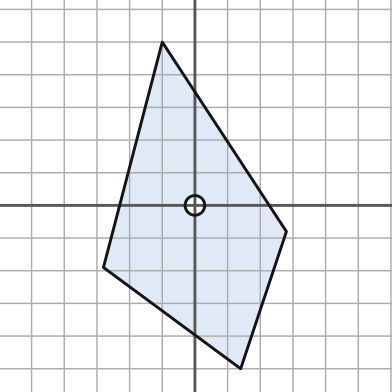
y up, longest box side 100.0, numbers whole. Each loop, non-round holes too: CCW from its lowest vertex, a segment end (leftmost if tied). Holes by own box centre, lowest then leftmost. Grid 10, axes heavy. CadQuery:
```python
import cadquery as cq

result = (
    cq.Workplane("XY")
    .moveTo(14.0, -50.0)
    .lineTo(28.0, -8.0)
    .lineTo(-10.0, 50.0)
    .lineTo(-28.0, -19.0)
    .close()
    .moveTo(0.0, 0.0)
    .circle(3.0)
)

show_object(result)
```